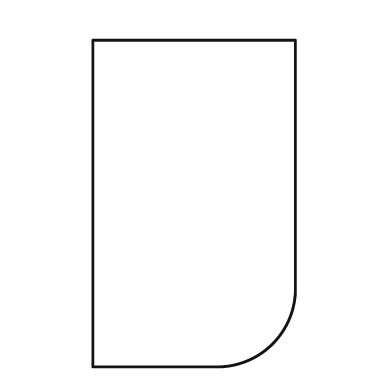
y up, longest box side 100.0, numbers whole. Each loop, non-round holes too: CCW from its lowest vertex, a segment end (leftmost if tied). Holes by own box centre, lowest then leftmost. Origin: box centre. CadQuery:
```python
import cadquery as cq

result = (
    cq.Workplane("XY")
    .moveTo(-31.0, -50.0)
    .lineTo(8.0, -50.0)
    .threePointArc((24.0, -43.0), (31.0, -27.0))
    .lineTo(31.0, 50.0)
    .lineTo(-31.0, 50.0)
    .close()
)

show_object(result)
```